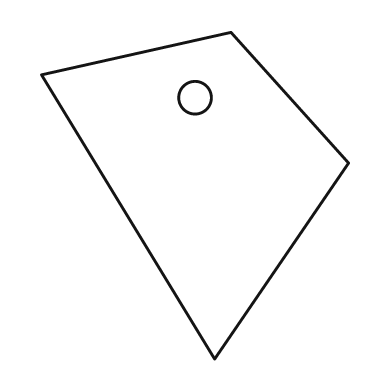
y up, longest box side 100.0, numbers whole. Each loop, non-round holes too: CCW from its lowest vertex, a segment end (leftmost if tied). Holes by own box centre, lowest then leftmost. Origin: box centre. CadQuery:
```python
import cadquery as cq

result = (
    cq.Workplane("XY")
    .moveTo(6.0, -50.0)
    .lineTo(47.0, 10.0)
    .lineTo(11.0, 50.0)
    .lineTo(-47.0, 37.0)
    .close()
    .moveTo(0.0, 30.0)
    .circle(5.0)
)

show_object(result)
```